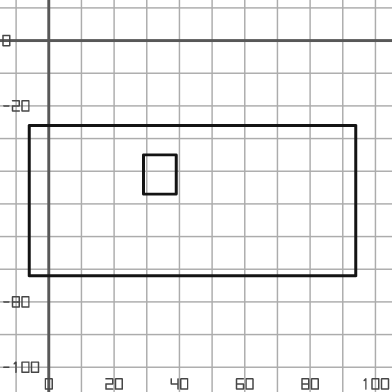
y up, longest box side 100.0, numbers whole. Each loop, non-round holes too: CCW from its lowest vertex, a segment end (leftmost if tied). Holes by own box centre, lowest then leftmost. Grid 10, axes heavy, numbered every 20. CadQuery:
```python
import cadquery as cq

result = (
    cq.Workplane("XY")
    .moveTo(-6.0, -72.0)
    .lineTo(94.0, -72.0)
    .lineTo(94.0, -26.0)
    .lineTo(-6.0, -26.0)
    .close()
    .moveTo(29.0, -47.0)
    .lineTo(39.0, -47.0)
    .lineTo(39.0, -35.0)
    .lineTo(29.0, -35.0)
    .close()
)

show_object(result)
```